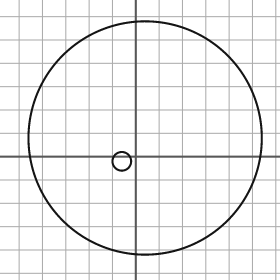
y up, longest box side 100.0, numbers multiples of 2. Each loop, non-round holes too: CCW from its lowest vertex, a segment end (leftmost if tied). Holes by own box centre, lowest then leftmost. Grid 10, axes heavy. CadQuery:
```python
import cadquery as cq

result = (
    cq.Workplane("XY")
    .moveTo(4.0, 8.0)
    .circle(50.0)
    .moveTo(-6.0, -2.0)
    .circle(4.0)
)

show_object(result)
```